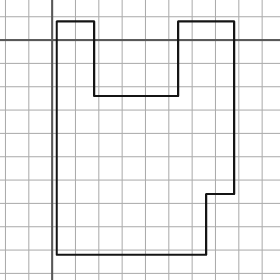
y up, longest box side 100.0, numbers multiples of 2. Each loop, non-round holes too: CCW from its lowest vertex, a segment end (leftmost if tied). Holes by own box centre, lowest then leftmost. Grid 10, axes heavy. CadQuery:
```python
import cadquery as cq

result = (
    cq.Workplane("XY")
    .moveTo(2.0, -92.0)
    .lineTo(66.0, -92.0)
    .lineTo(66.0, -66.0)
    .lineTo(78.0, -66.0)
    .lineTo(78.0, 8.0)
    .lineTo(54.0, 8.0)
    .lineTo(54.0, -24.0)
    .lineTo(18.0, -24.0)
    .lineTo(18.0, 8.0)
    .lineTo(2.0, 8.0)
    .close()
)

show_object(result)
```